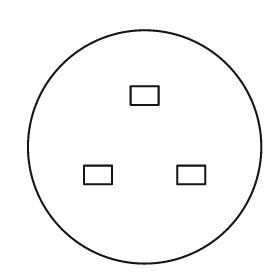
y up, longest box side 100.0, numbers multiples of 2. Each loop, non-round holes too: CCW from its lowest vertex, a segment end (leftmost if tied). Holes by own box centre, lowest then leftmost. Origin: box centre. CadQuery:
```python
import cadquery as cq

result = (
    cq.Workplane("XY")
    .moveTo(0.0, 0.0)
    .circle(50.0)
    .moveTo(-26.0, -16.0)
    .lineTo(-14.0, -16.0)
    .lineTo(-14.0, -8.0)
    .lineTo(-26.0, -8.0)
    .close()
    .moveTo(14.0, -16.0)
    .lineTo(26.0, -16.0)
    .lineTo(26.0, -8.0)
    .lineTo(14.0, -8.0)
    .close()
    .moveTo(-6.0, 18.0)
    .lineTo(6.0, 18.0)
    .lineTo(6.0, 26.0)
    .lineTo(-6.0, 26.0)
    .close()
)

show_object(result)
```